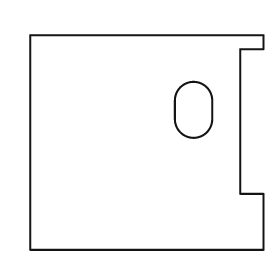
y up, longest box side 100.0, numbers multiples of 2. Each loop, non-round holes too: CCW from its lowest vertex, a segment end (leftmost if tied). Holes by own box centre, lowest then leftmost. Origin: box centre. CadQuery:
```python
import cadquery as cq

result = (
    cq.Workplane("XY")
    .moveTo(-50.0, -46.0)
    .lineTo(50.0, -46.0)
    .lineTo(50.0, -22.0)
    .lineTo(40.0, -22.0)
    .lineTo(40.0, 40.0)
    .lineTo(50.0, 40.0)
    .lineTo(50.0, 46.0)
    .lineTo(-50.0, 46.0)
    .close()
    .moveTo(12.0, 10.0)
    .threePointArc((20.0, 2.0), (28.0, 10.0))
    .lineTo(28.0, 18.0)
    .threePointArc((20.0, 26.0), (12.0, 18.0))
    .close()
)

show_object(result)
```